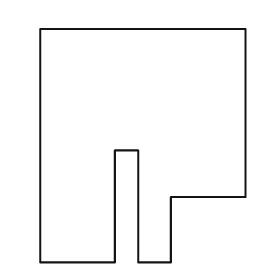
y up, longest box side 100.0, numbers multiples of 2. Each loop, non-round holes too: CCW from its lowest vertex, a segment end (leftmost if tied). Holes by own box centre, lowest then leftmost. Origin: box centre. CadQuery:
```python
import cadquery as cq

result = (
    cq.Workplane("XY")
    .moveTo(-44.0, -50.0)
    .lineTo(-12.0, -50.0)
    .lineTo(-12.0, -2.0)
    .lineTo(-2.0, -2.0)
    .lineTo(-2.0, -50.0)
    .lineTo(12.0, -50.0)
    .lineTo(12.0, -22.0)
    .lineTo(44.0, -22.0)
    .lineTo(44.0, 50.0)
    .lineTo(-44.0, 50.0)
    .close()
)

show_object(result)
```